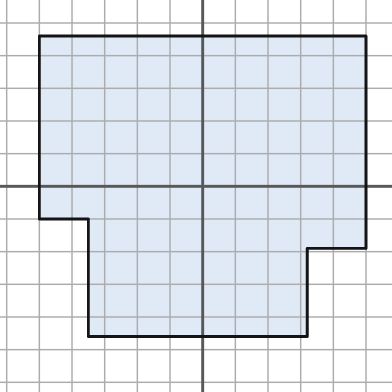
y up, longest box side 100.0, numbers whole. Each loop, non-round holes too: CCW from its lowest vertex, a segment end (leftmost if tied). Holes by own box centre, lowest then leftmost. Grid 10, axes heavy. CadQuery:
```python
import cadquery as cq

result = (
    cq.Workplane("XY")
    .moveTo(-35.0, -46.0)
    .lineTo(32.0, -46.0)
    .lineTo(32.0, -19.0)
    .lineTo(50.0, -19.0)
    .lineTo(50.0, 46.0)
    .lineTo(-50.0, 46.0)
    .lineTo(-50.0, -10.0)
    .lineTo(-35.0, -10.0)
    .close()
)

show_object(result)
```